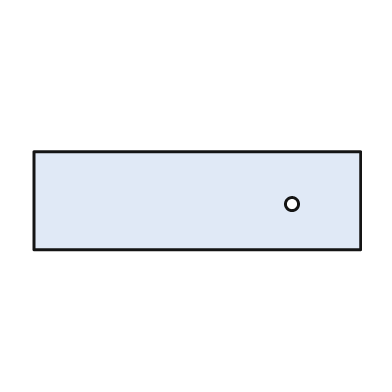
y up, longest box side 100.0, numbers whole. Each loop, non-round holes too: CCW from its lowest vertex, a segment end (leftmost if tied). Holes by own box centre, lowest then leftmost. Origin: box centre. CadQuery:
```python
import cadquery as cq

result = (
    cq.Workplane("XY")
    .moveTo(-50.0, -15.0)
    .lineTo(50.0, -15.0)
    .lineTo(50.0, 15.0)
    .lineTo(-50.0, 15.0)
    .close()
    .moveTo(29.0, -1.0)
    .circle(2.0)
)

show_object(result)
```